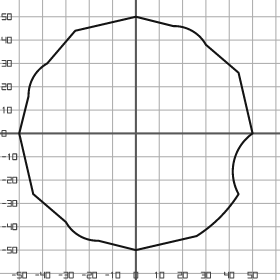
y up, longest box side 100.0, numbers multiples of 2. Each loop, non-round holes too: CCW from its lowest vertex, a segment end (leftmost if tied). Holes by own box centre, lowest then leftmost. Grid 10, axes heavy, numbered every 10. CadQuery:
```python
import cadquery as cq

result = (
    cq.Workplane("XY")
    .moveTo(0.0, -50.0)
    .lineTo(26.0, -44.0)
    .threePointArc((36.0, -36.0), (44.0, -26.0))
    .threePointArc((42.0, -12.0), (50.0, 0.0))
    .lineTo(44.0, 26.0)
    .lineTo(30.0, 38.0)
    .threePointArc((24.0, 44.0), (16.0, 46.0))
    .lineTo(0.0, 50.0)
    .lineTo(-26.0, 44.0)
    .lineTo(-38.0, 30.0)
    .threePointArc((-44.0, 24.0), (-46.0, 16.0))
    .lineTo(-50.0, 0.0)
    .lineTo(-44.0, -26.0)
    .lineTo(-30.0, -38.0)
    .threePointArc((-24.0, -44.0), (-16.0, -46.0))
    .close()
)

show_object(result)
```